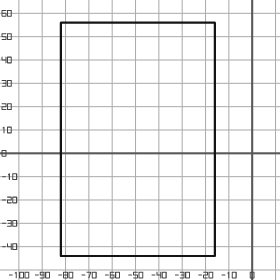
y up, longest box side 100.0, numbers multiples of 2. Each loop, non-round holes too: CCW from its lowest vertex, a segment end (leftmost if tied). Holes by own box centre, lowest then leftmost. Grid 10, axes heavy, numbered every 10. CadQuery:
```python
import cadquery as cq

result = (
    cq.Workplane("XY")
    .moveTo(-82.0, -44.0)
    .lineTo(-16.0, -44.0)
    .lineTo(-16.0, 56.0)
    .lineTo(-82.0, 56.0)
    .close()
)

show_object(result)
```